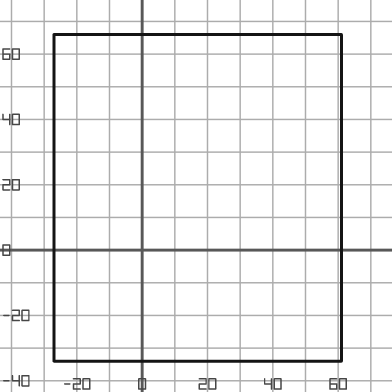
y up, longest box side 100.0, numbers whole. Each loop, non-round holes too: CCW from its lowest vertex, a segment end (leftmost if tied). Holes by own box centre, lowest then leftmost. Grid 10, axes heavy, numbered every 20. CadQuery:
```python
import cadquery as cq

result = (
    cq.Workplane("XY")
    .moveTo(-27.0, -34.0)
    .lineTo(61.0, -34.0)
    .lineTo(61.0, 66.0)
    .lineTo(-27.0, 66.0)
    .close()
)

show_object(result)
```